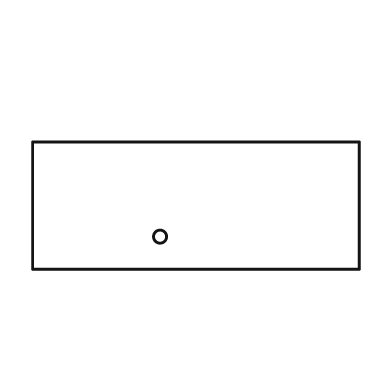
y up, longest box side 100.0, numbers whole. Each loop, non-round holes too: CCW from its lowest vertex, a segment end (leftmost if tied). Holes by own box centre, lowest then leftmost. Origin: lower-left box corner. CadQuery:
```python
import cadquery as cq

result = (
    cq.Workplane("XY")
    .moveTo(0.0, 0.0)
    .lineTo(100.0, 0.0)
    .lineTo(100.0, 39.0)
    .lineTo(0.0, 39.0)
    .close()
    .moveTo(39.0, 10.0)
    .circle(2.0)
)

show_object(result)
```